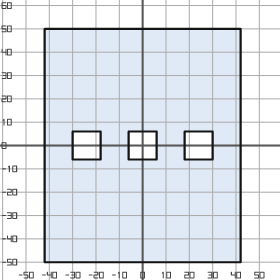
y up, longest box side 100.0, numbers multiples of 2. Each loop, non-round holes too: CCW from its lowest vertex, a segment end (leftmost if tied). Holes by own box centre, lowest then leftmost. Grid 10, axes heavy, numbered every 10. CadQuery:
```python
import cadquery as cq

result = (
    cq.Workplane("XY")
    .moveTo(-42.0, -50.0)
    .lineTo(42.0, -50.0)
    .lineTo(42.0, 50.0)
    .lineTo(-42.0, 50.0)
    .close()
    .moveTo(-30.0, -6.0)
    .lineTo(-18.0, -6.0)
    .lineTo(-18.0, 6.0)
    .lineTo(-30.0, 6.0)
    .close()
    .moveTo(-6.0, -6.0)
    .lineTo(6.0, -6.0)
    .lineTo(6.0, 6.0)
    .lineTo(-6.0, 6.0)
    .close()
    .moveTo(18.0, -6.0)
    .lineTo(30.0, -6.0)
    .lineTo(30.0, 6.0)
    .lineTo(18.0, 6.0)
    .close()
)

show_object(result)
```